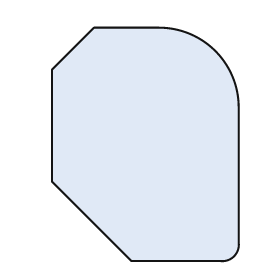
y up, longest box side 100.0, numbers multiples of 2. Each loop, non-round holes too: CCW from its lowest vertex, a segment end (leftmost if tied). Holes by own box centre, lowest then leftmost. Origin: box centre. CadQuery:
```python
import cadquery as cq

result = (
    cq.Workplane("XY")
    .moveTo(-6.0, -50.0)
    .lineTo(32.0, -50.0)
    .threePointArc((38.0, -48.0), (40.0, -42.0))
    .lineTo(40.0, 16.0)
    .threePointArc((30.0, 40.0), (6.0, 50.0))
    .lineTo(-22.0, 50.0)
    .lineTo(-40.0, 32.0)
    .lineTo(-40.0, -16.0)
    .close()
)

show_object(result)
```